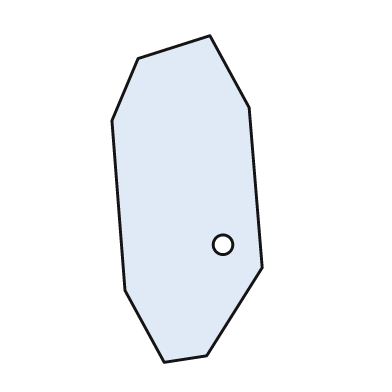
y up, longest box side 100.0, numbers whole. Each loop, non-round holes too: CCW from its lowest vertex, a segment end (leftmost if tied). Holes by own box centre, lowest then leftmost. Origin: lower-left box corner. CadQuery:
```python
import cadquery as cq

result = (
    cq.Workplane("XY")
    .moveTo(16.0, 0.0)
    .lineTo(29.0, 2.0)
    .lineTo(46.0, 29.0)
    .lineTo(42.0, 78.0)
    .lineTo(30.0, 100.0)
    .lineTo(8.0, 93.0)
    .lineTo(0.0, 74.0)
    .lineTo(4.0, 22.0)
    .close()
    .moveTo(34.0, 36.0)
    .circle(3.0)
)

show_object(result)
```